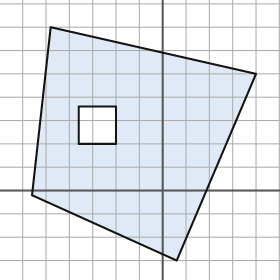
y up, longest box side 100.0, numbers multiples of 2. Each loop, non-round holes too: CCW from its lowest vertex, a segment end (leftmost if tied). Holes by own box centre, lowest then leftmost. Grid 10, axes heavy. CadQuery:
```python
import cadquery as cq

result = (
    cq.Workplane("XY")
    .moveTo(6.0, -30.0)
    .lineTo(40.0, 50.0)
    .lineTo(-48.0, 70.0)
    .lineTo(-56.0, -2.0)
    .close()
    .moveTo(-36.0, 20.0)
    .lineTo(-20.0, 20.0)
    .lineTo(-20.0, 36.0)
    .lineTo(-36.0, 36.0)
    .close()
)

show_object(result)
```